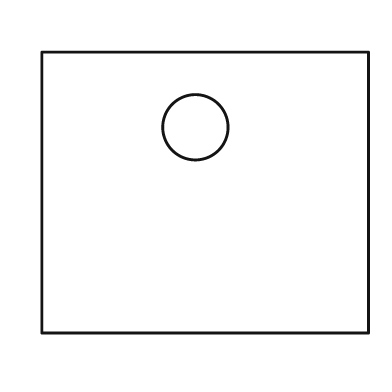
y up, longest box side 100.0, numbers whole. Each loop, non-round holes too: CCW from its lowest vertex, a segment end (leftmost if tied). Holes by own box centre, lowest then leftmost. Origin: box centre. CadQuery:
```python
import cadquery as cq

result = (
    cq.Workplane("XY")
    .moveTo(-50.0, -43.0)
    .lineTo(50.0, -43.0)
    .lineTo(50.0, 43.0)
    .lineTo(-50.0, 43.0)
    .close()
    .moveTo(-3.0, 20.0)
    .circle(10.0)
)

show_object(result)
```